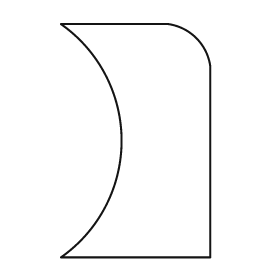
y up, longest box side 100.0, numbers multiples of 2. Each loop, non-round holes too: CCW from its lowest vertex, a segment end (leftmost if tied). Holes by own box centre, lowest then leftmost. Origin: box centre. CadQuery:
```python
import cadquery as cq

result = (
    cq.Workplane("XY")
    .moveTo(-32.0, -50.0)
    .lineTo(32.0, -50.0)
    .lineTo(32.0, 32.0)
    .threePointArc((26.0, 44.0), (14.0, 50.0))
    .lineTo(-32.0, 50.0)
    .threePointArc((-6.0, 0.0), (-32.0, -50.0))
    .close()
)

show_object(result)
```